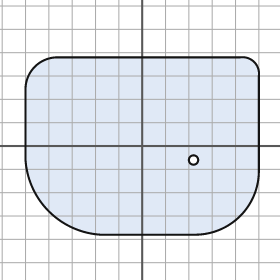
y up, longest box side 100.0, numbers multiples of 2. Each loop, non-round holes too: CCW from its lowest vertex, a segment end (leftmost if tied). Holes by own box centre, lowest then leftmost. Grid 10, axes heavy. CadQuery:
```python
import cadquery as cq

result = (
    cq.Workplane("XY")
    .moveTo(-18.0, -38.0)
    .lineTo(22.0, -38.0)
    .threePointArc((42.0, -30.0), (50.0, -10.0))
    .lineTo(50.0, 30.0)
    .threePointArc((48.0, 36.0), (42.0, 38.0))
    .lineTo(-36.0, 38.0)
    .threePointArc((-46.0, 34.0), (-50.0, 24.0))
    .lineTo(-50.0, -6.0)
    .threePointArc((-40.0, -28.0), (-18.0, -38.0))
    .close()
    .moveTo(22.0, -6.0)
    .circle(2.0)
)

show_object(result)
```